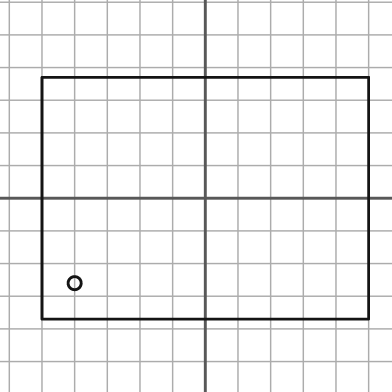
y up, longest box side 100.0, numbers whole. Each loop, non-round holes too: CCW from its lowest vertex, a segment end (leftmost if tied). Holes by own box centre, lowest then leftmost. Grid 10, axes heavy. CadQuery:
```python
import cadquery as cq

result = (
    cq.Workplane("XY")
    .moveTo(-50.0, -37.0)
    .lineTo(50.0, -37.0)
    .lineTo(50.0, 37.0)
    .lineTo(-50.0, 37.0)
    .close()
    .moveTo(-40.0, -26.0)
    .circle(2.0)
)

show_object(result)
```